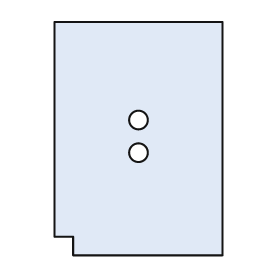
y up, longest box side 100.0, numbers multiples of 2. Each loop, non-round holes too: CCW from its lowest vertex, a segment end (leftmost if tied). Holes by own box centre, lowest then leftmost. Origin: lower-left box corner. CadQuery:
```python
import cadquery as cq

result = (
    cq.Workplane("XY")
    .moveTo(8.0, 0.0)
    .lineTo(72.0, 0.0)
    .lineTo(72.0, 100.0)
    .lineTo(0.0, 100.0)
    .lineTo(0.0, 8.0)
    .lineTo(8.0, 8.0)
    .close()
    .moveTo(36.0, 44.0)
    .circle(4.0)
    .moveTo(36.0, 58.0)
    .circle(4.0)
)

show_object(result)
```